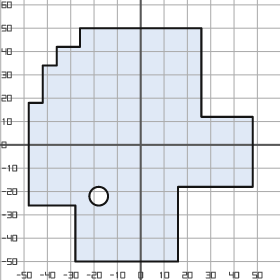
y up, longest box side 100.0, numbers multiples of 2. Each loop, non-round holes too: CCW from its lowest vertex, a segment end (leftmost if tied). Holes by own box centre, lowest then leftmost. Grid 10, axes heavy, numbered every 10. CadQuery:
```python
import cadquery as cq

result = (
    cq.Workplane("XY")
    .moveTo(-28.0, -50.0)
    .lineTo(16.0, -50.0)
    .lineTo(16.0, -18.0)
    .lineTo(48.0, -18.0)
    .lineTo(48.0, 12.0)
    .lineTo(26.0, 12.0)
    .lineTo(26.0, 50.0)
    .lineTo(-26.0, 50.0)
    .lineTo(-26.0, 42.0)
    .lineTo(-36.0, 42.0)
    .lineTo(-36.0, 34.0)
    .lineTo(-42.0, 34.0)
    .lineTo(-42.0, 18.0)
    .lineTo(-48.0, 18.0)
    .lineTo(-48.0, -26.0)
    .lineTo(-28.0, -26.0)
    .close()
    .moveTo(-18.0, -22.0)
    .circle(4.0)
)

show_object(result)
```